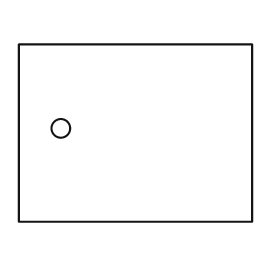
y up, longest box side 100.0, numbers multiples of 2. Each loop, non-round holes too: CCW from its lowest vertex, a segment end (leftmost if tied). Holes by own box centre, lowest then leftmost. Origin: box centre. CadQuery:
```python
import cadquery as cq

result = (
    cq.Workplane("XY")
    .moveTo(-50.0, -38.0)
    .lineTo(50.0, -38.0)
    .lineTo(50.0, 38.0)
    .lineTo(-50.0, 38.0)
    .close()
    .moveTo(-32.0, 2.0)
    .circle(4.0)
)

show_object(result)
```